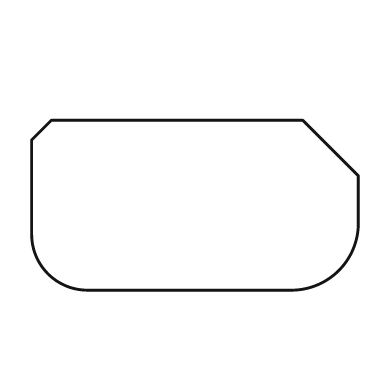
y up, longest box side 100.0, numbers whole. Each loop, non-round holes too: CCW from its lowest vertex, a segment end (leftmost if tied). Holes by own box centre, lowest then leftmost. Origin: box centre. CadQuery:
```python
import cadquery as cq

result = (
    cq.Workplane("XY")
    .moveTo(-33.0, -26.0)
    .lineTo(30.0, -26.0)
    .threePointArc((44.0, -20.0), (50.0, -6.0))
    .lineTo(50.0, 9.0)
    .lineTo(33.0, 26.0)
    .lineTo(-44.0, 26.0)
    .lineTo(-50.0, 20.0)
    .lineTo(-50.0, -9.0)
    .threePointArc((-45.0, -21.0), (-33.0, -26.0))
    .close()
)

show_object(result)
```